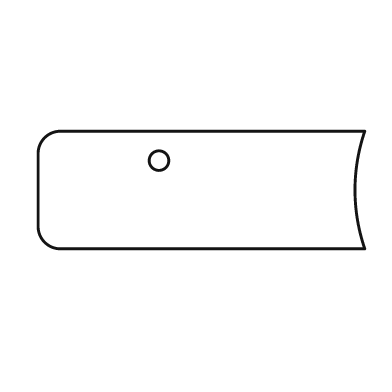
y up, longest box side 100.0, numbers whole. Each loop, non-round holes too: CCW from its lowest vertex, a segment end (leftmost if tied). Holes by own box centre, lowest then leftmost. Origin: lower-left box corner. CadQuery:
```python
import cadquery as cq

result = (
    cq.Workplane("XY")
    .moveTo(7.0, 0.0)
    .lineTo(100.0, 0.0)
    .threePointArc((97.0, 18.0), (100.0, 36.0))
    .lineTo(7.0, 36.0)
    .threePointArc((2.0, 34.0), (0.0, 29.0))
    .lineTo(0.0, 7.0)
    .threePointArc((2.0, 2.0), (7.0, 0.0))
    .close()
    .moveTo(37.0, 27.0)
    .circle(3.0)
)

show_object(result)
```